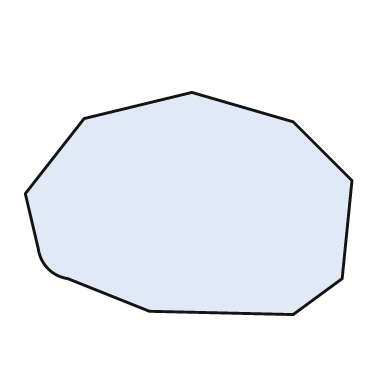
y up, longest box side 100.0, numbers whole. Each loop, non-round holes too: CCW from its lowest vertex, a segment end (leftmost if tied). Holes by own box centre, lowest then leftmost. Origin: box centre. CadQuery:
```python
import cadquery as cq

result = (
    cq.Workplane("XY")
    .moveTo(32.0, -34.0)
    .lineTo(47.0, -23.0)
    .lineTo(50.0, 7.0)
    .lineTo(32.0, 25.0)
    .lineTo(1.0, 34.0)
    .lineTo(-32.0, 26.0)
    .lineTo(-50.0, 3.0)
    .lineTo(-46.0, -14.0)
    .threePointArc((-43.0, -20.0), (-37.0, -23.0))
    .lineTo(-12.0, -33.0)
    .close()
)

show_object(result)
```